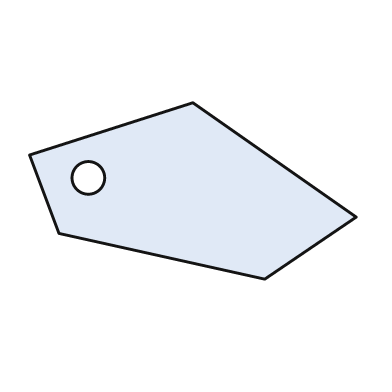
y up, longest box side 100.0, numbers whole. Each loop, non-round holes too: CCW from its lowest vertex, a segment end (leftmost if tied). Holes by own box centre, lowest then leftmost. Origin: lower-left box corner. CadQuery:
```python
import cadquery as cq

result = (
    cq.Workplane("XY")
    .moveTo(72.0, 0.0)
    .lineTo(100.0, 19.0)
    .lineTo(50.0, 54.0)
    .lineTo(0.0, 38.0)
    .lineTo(9.0, 14.0)
    .close()
    .moveTo(18.0, 31.0)
    .circle(5.0)
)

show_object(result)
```